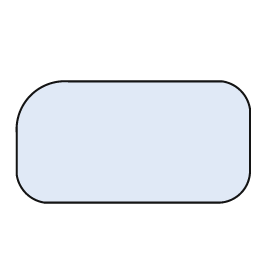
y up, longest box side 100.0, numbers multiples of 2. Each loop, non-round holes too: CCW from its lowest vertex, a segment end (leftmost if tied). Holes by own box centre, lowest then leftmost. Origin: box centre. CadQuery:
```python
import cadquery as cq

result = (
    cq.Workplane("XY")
    .moveTo(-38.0, -26.0)
    .lineTo(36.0, -26.0)
    .threePointArc((46.0, -22.0), (50.0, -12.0))
    .lineTo(50.0, 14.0)
    .threePointArc((46.0, 22.0), (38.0, 26.0))
    .lineTo(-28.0, 26.0)
    .threePointArc((-44.0, 20.0), (-50.0, 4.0))
    .lineTo(-50.0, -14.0)
    .threePointArc((-46.0, -22.0), (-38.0, -26.0))
    .close()
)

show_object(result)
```